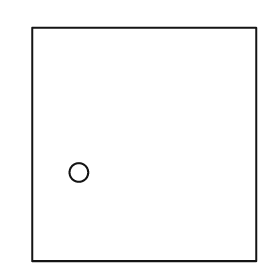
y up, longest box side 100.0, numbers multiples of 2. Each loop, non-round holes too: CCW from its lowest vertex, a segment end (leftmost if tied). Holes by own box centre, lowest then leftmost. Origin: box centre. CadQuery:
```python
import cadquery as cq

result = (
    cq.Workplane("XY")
    .moveTo(-48.0, -50.0)
    .lineTo(48.0, -50.0)
    .lineTo(48.0, 50.0)
    .lineTo(-48.0, 50.0)
    .close()
    .moveTo(-28.0, -12.0)
    .circle(4.0)
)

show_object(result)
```